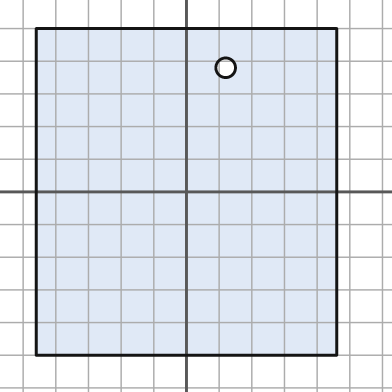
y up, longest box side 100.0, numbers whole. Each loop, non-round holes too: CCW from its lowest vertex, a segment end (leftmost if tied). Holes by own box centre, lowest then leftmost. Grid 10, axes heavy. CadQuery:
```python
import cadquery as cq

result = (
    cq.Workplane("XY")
    .moveTo(-46.0, -50.0)
    .lineTo(46.0, -50.0)
    .lineTo(46.0, 50.0)
    .lineTo(-46.0, 50.0)
    .close()
    .moveTo(12.0, 38.0)
    .circle(3.0)
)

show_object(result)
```